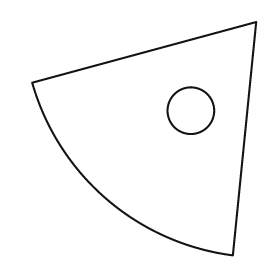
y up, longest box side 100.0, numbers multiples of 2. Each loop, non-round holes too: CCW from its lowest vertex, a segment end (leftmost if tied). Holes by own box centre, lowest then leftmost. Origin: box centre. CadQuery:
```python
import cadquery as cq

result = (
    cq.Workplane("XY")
    .moveTo(38.0, -50.0)
    .lineTo(48.0, 50.0)
    .lineTo(-48.0, 24.0)
    .threePointArc((-16.0, -26.0), (38.0, -50.0))
    .close()
    .moveTo(20.0, 12.0)
    .circle(10.0)
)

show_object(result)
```